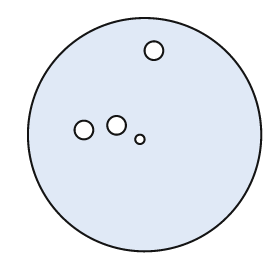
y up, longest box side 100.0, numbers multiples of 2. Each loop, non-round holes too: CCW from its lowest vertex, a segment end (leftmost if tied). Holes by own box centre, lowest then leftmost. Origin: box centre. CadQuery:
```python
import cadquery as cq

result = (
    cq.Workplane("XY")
    .moveTo(0.0, 0.0)
    .circle(50.0)
    .moveTo(-2.0, -2.0)
    .circle(2.0)
    .moveTo(-26.0, 2.0)
    .circle(4.0)
    .moveTo(-12.0, 4.0)
    .circle(4.0)
    .moveTo(4.0, 36.0)
    .circle(4.0)
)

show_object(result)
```